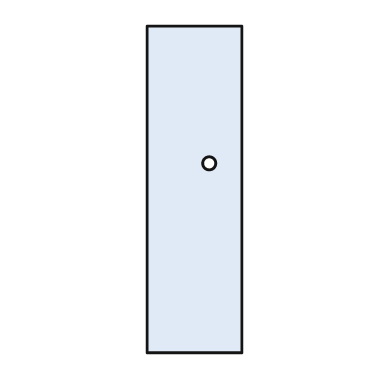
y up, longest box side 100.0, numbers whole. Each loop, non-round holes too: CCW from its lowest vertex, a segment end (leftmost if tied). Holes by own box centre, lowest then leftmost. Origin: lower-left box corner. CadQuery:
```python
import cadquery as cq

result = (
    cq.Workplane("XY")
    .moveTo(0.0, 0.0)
    .lineTo(29.0, 0.0)
    .lineTo(29.0, 100.0)
    .lineTo(0.0, 100.0)
    .close()
    .moveTo(19.0, 58.0)
    .circle(2.0)
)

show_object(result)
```